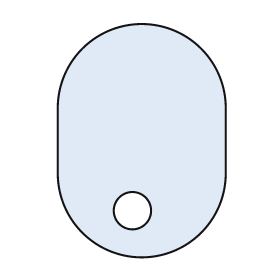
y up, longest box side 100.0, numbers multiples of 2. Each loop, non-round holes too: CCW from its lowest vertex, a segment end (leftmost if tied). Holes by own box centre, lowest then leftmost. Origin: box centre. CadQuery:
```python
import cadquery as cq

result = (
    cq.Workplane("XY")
    .moveTo(-36.0, -14.0)
    .threePointArc((0.0, -50.0), (36.0, -14.0))
    .lineTo(36.0, 14.0)
    .threePointArc((0.0, 50.0), (-36.0, 14.0))
    .close()
    .moveTo(-4.0, -30.0)
    .circle(8.0)
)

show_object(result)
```